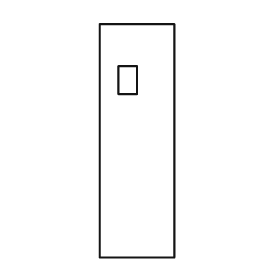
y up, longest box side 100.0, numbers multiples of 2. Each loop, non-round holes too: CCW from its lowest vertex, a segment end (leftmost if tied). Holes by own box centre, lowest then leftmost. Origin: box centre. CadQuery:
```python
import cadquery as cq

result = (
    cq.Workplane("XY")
    .moveTo(-16.0, -50.0)
    .lineTo(16.0, -50.0)
    .lineTo(16.0, 50.0)
    .lineTo(-16.0, 50.0)
    .close()
    .moveTo(-8.0, 20.0)
    .lineTo(0.0, 20.0)
    .lineTo(0.0, 32.0)
    .lineTo(-8.0, 32.0)
    .close()
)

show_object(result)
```